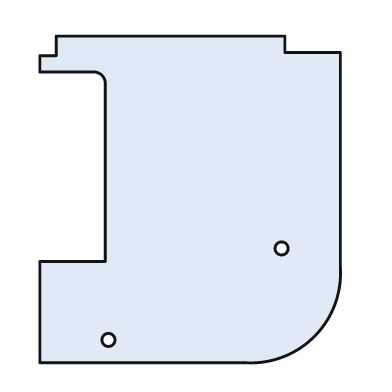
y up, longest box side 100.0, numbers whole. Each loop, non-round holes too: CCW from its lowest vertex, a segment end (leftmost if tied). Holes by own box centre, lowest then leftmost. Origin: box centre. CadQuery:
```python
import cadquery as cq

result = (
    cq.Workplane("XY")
    .moveTo(-46.0, -50.0)
    .lineTo(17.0, -50.0)
    .threePointArc((38.0, -42.0), (46.0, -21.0))
    .lineTo(46.0, 45.0)
    .lineTo(29.0, 45.0)
    .lineTo(29.0, 50.0)
    .lineTo(-41.0, 50.0)
    .lineTo(-41.0, 44.0)
    .lineTo(-46.0, 44.0)
    .lineTo(-46.0, 39.0)
    .lineTo(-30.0, 39.0)
    .threePointArc((-27.0, 38.0), (-26.0, 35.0))
    .lineTo(-26.0, -19.0)
    .lineTo(-46.0, -19.0)
    .close()
    .moveTo(-25.0, -43.0)
    .circle(2.0)
    .moveTo(28.0, -15.0)
    .circle(2.0)
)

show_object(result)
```